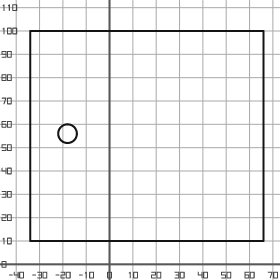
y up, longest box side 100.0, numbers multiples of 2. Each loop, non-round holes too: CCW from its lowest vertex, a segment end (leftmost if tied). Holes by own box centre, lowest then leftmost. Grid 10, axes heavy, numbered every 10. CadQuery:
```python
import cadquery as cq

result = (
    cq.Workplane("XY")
    .moveTo(-34.0, 10.0)
    .lineTo(66.0, 10.0)
    .lineTo(66.0, 100.0)
    .lineTo(-34.0, 100.0)
    .close()
    .moveTo(-18.0, 56.0)
    .circle(4.0)
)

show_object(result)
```